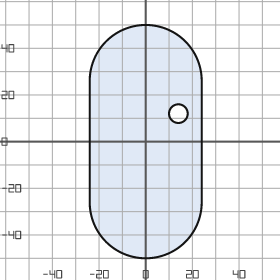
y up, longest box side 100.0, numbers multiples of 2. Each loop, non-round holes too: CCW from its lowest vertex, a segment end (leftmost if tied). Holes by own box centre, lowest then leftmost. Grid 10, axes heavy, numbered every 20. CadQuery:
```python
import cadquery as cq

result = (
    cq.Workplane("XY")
    .moveTo(-24.0, -26.0)
    .threePointArc((0.0, -50.0), (24.0, -26.0))
    .lineTo(24.0, 26.0)
    .threePointArc((0.0, 50.0), (-24.0, 26.0))
    .close()
    .moveTo(14.0, 12.0)
    .circle(4.0)
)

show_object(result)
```